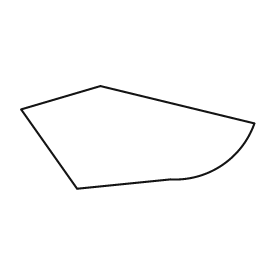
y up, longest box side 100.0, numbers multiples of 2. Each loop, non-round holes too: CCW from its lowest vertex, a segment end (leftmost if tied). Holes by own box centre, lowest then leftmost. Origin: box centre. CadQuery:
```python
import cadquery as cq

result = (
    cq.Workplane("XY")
    .moveTo(-26.0, -22.0)
    .lineTo(14.0, -18.0)
    .threePointArc((36.0, -12.0), (50.0, 6.0))
    .lineTo(-16.0, 22.0)
    .lineTo(-50.0, 12.0)
    .close()
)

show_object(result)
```